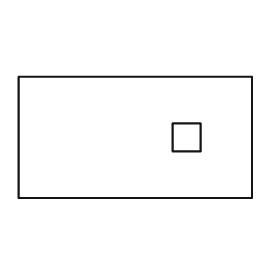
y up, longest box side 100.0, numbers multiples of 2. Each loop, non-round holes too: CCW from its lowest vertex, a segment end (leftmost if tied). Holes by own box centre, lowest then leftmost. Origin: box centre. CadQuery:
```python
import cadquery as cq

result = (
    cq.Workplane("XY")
    .moveTo(-50.0, -26.0)
    .lineTo(50.0, -26.0)
    .lineTo(50.0, 26.0)
    .lineTo(-50.0, 26.0)
    .close()
    .moveTo(16.0, -6.0)
    .lineTo(28.0, -6.0)
    .lineTo(28.0, 6.0)
    .lineTo(16.0, 6.0)
    .close()
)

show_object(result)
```